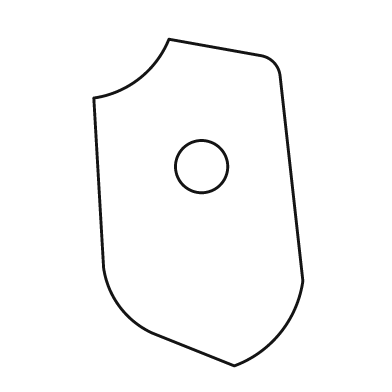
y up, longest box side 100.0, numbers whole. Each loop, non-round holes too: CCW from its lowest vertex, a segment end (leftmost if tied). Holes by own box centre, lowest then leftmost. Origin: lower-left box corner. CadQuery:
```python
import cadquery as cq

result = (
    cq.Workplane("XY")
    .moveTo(43.0, 0.0)
    .threePointArc((57.0, 10.0), (64.0, 26.0))
    .lineTo(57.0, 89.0)
    .threePointArc((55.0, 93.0), (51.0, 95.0))
    .lineTo(23.0, 100.0)
    .threePointArc((14.0, 88.0), (0.0, 82.0))
    .lineTo(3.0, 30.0)
    .threePointArc((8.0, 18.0), (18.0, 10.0))
    .close()
    .moveTo(33.0, 61.0)
    .circle(8.0)
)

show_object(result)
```